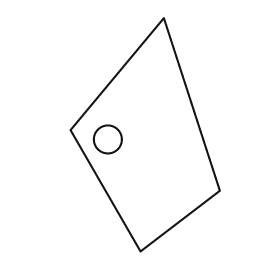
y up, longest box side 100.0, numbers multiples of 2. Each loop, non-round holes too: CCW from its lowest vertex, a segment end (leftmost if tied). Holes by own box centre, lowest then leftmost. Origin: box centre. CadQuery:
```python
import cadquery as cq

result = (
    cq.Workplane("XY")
    .moveTo(-2.0, -50.0)
    .lineTo(32.0, -24.0)
    .lineTo(8.0, 50.0)
    .lineTo(-32.0, 2.0)
    .close()
    .moveTo(-16.0, -2.0)
    .circle(6.0)
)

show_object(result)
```